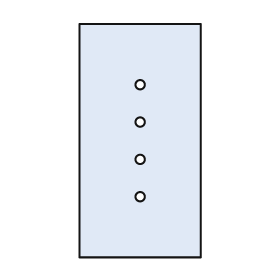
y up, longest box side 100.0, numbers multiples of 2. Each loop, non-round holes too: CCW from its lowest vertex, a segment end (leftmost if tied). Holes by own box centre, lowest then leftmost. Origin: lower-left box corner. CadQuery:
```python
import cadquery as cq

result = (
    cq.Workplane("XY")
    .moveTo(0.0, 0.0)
    .lineTo(52.0, 0.0)
    .lineTo(52.0, 100.0)
    .lineTo(0.0, 100.0)
    .close()
    .moveTo(26.0, 26.0)
    .circle(2.0)
    .moveTo(26.0, 42.0)
    .circle(2.0)
    .moveTo(26.0, 58.0)
    .circle(2.0)
    .moveTo(26.0, 74.0)
    .circle(2.0)
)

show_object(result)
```